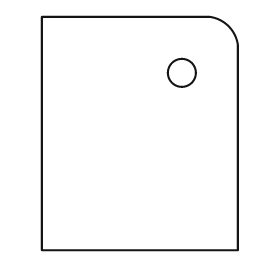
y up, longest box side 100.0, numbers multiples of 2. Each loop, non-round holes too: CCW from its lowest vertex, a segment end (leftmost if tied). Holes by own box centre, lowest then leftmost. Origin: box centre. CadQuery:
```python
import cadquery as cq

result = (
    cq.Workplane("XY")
    .moveTo(-42.0, -50.0)
    .lineTo(42.0, -50.0)
    .lineTo(42.0, 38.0)
    .threePointArc((38.0, 46.0), (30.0, 50.0))
    .lineTo(-42.0, 50.0)
    .close()
    .moveTo(18.0, 26.0)
    .circle(6.0)
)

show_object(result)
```